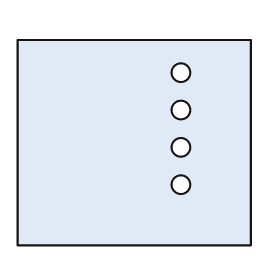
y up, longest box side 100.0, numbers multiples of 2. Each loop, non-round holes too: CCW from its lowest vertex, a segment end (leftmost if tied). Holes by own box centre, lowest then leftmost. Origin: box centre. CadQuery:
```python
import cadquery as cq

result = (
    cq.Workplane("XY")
    .moveTo(-50.0, -44.0)
    .lineTo(50.0, -44.0)
    .lineTo(50.0, 44.0)
    .lineTo(-50.0, 44.0)
    .close()
    .moveTo(20.0, -18.0)
    .circle(4.0)
    .moveTo(20.0, -2.0)
    .circle(4.0)
    .moveTo(20.0, 14.0)
    .circle(4.0)
    .moveTo(20.0, 30.0)
    .circle(4.0)
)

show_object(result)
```